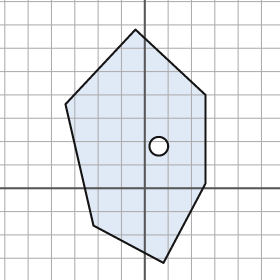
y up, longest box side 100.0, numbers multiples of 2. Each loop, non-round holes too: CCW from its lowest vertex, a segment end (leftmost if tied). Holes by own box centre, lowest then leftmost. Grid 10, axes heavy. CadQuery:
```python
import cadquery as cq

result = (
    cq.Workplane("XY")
    .moveTo(8.0, -32.0)
    .lineTo(26.0, 2.0)
    .lineTo(26.0, 40.0)
    .lineTo(-4.0, 68.0)
    .lineTo(-34.0, 36.0)
    .lineTo(-22.0, -16.0)
    .close()
    .moveTo(6.0, 18.0)
    .circle(4.0)
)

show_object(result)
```